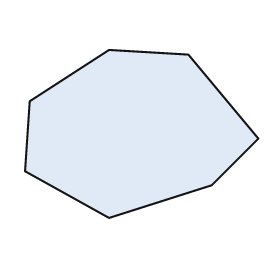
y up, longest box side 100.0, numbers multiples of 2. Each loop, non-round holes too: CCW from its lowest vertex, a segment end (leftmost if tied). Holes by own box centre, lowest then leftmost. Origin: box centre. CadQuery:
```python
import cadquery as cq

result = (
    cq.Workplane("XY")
    .moveTo(-14.0, -36.0)
    .lineTo(30.0, -22.0)
    .lineTo(50.0, -2.0)
    .lineTo(20.0, 34.0)
    .lineTo(-14.0, 36.0)
    .lineTo(-48.0, 14.0)
    .lineTo(-50.0, -16.0)
    .close()
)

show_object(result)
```